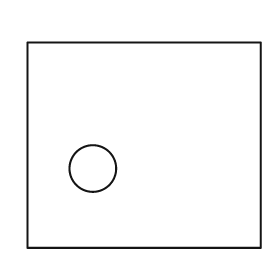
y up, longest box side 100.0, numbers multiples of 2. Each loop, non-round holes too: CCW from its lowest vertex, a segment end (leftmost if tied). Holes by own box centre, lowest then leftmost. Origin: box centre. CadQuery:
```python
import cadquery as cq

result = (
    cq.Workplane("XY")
    .moveTo(-50.0, -44.0)
    .lineTo(50.0, -44.0)
    .lineTo(50.0, 44.0)
    .lineTo(-50.0, 44.0)
    .close()
    .moveTo(-22.0, -10.0)
    .circle(10.0)
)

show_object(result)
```